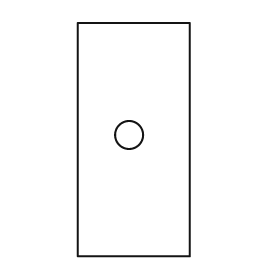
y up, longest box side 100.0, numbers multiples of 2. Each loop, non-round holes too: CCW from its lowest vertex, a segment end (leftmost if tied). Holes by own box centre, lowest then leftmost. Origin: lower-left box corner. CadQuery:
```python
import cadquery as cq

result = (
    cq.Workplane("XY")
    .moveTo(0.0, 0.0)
    .lineTo(48.0, 0.0)
    .lineTo(48.0, 100.0)
    .lineTo(0.0, 100.0)
    .close()
    .moveTo(22.0, 52.0)
    .circle(6.0)
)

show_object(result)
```